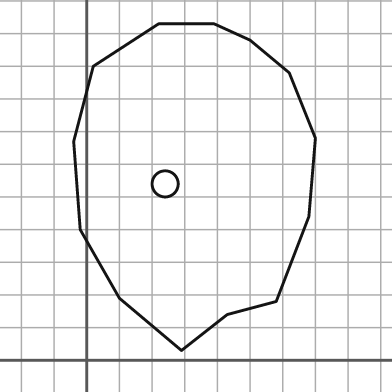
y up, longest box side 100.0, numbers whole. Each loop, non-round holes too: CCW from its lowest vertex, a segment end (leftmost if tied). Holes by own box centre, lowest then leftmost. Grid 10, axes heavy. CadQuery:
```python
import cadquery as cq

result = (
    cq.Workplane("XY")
    .moveTo(29.0, 3.0)
    .lineTo(43.0, 14.0)
    .lineTo(58.0, 18.0)
    .lineTo(68.0, 44.0)
    .lineTo(70.0, 68.0)
    .lineTo(62.0, 88.0)
    .lineTo(50.0, 98.0)
    .lineTo(39.0, 103.0)
    .lineTo(22.0, 103.0)
    .lineTo(2.0, 90.0)
    .lineTo(-4.0, 67.0)
    .lineTo(-2.0, 40.0)
    .lineTo(10.0, 19.0)
    .close()
    .moveTo(24.0, 54.0)
    .circle(4.0)
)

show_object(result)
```